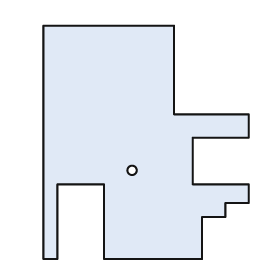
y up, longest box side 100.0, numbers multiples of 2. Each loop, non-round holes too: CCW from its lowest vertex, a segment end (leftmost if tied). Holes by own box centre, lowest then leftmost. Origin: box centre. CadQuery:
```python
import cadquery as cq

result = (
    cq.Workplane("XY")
    .moveTo(-44.0, -50.0)
    .lineTo(-38.0, -50.0)
    .lineTo(-38.0, -18.0)
    .lineTo(-18.0, -18.0)
    .lineTo(-18.0, -50.0)
    .lineTo(24.0, -50.0)
    .lineTo(24.0, -32.0)
    .lineTo(34.0, -32.0)
    .lineTo(34.0, -26.0)
    .lineTo(44.0, -26.0)
    .lineTo(44.0, -18.0)
    .lineTo(20.0, -18.0)
    .lineTo(20.0, 2.0)
    .lineTo(44.0, 2.0)
    .lineTo(44.0, 12.0)
    .lineTo(12.0, 12.0)
    .lineTo(12.0, 50.0)
    .lineTo(-44.0, 50.0)
    .close()
    .moveTo(-6.0, -12.0)
    .circle(2.0)
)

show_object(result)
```